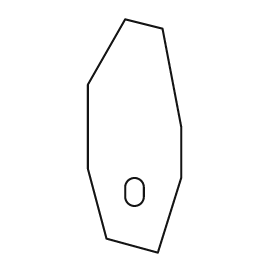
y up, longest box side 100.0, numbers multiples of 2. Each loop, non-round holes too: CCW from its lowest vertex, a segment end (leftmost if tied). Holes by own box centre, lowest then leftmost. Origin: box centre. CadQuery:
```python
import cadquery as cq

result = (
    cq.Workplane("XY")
    .moveTo(10.0, -50.0)
    .lineTo(20.0, -18.0)
    .lineTo(20.0, 4.0)
    .lineTo(12.0, 46.0)
    .lineTo(-4.0, 50.0)
    .lineTo(-20.0, 22.0)
    .lineTo(-20.0, -14.0)
    .lineTo(-12.0, -44.0)
    .close()
    .moveTo(-4.0, -26.0)
    .threePointArc((0.0, -30.0), (4.0, -26.0))
    .lineTo(4.0, -22.0)
    .threePointArc((0.0, -18.0), (-4.0, -22.0))
    .close()
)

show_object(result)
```